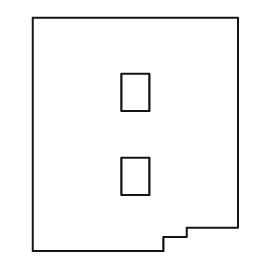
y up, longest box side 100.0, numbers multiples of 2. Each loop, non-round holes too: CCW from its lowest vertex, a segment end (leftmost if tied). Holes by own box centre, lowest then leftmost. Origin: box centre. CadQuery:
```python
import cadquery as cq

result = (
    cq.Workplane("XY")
    .moveTo(-44.0, -50.0)
    .lineTo(12.0, -50.0)
    .lineTo(12.0, -44.0)
    .lineTo(22.0, -44.0)
    .lineTo(22.0, -40.0)
    .lineTo(44.0, -40.0)
    .lineTo(44.0, 50.0)
    .lineTo(-44.0, 50.0)
    .close()
    .moveTo(-6.0, -26.0)
    .lineTo(6.0, -26.0)
    .lineTo(6.0, -10.0)
    .lineTo(-6.0, -10.0)
    .close()
    .moveTo(-6.0, 10.0)
    .lineTo(6.0, 10.0)
    .lineTo(6.0, 26.0)
    .lineTo(-6.0, 26.0)
    .close()
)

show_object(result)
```